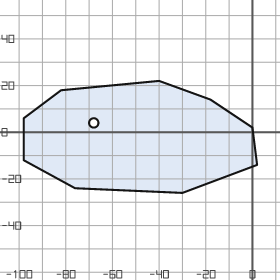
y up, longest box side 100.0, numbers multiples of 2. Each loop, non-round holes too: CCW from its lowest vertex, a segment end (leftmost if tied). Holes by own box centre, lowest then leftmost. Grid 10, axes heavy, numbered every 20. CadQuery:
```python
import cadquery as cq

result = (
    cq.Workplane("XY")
    .moveTo(-30.0, -26.0)
    .lineTo(2.0, -14.0)
    .lineTo(0.0, 2.0)
    .lineTo(-18.0, 14.0)
    .lineTo(-40.0, 22.0)
    .lineTo(-82.0, 18.0)
    .lineTo(-98.0, 6.0)
    .lineTo(-98.0, -12.0)
    .lineTo(-76.0, -24.0)
    .close()
    .moveTo(-68.0, 4.0)
    .circle(2.0)
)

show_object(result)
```